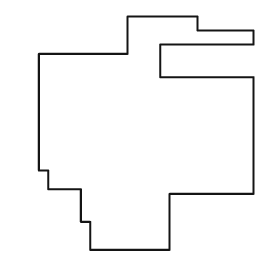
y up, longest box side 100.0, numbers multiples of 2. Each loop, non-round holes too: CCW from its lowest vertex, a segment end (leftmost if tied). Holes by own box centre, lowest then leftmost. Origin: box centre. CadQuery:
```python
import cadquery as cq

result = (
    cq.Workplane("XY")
    .moveTo(-24.0, -50.0)
    .lineTo(10.0, -50.0)
    .lineTo(10.0, -26.0)
    .lineTo(46.0, -26.0)
    .lineTo(46.0, 24.0)
    .lineTo(6.0, 24.0)
    .lineTo(6.0, 38.0)
    .lineTo(46.0, 38.0)
    .lineTo(46.0, 44.0)
    .lineTo(22.0, 44.0)
    .lineTo(22.0, 50.0)
    .lineTo(-8.0, 50.0)
    .lineTo(-8.0, 34.0)
    .lineTo(-46.0, 34.0)
    .lineTo(-46.0, -16.0)
    .lineTo(-42.0, -16.0)
    .lineTo(-42.0, -24.0)
    .lineTo(-28.0, -24.0)
    .lineTo(-28.0, -38.0)
    .lineTo(-24.0, -38.0)
    .close()
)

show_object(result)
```